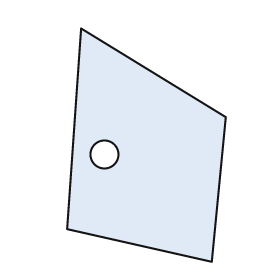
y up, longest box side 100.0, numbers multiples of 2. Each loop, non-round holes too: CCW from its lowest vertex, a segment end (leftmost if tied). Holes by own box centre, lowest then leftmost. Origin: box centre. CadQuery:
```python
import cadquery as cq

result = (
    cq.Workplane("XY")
    .moveTo(28.0, -50.0)
    .lineTo(34.0, 12.0)
    .lineTo(-28.0, 50.0)
    .lineTo(-34.0, -36.0)
    .close()
    .moveTo(-18.0, -4.0)
    .circle(6.0)
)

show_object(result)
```